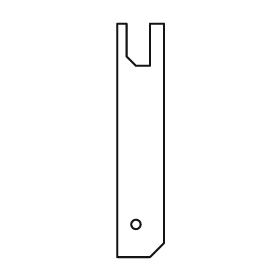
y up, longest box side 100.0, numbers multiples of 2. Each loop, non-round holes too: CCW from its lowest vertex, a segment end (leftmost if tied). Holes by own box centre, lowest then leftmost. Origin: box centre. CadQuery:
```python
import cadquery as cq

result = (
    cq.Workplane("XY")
    .moveTo(-10.0, -50.0)
    .lineTo(4.0, -50.0)
    .lineTo(10.0, -44.0)
    .lineTo(10.0, 50.0)
    .lineTo(4.0, 50.0)
    .lineTo(4.0, 32.0)
    .lineTo(-2.0, 32.0)
    .lineTo(-6.0, 36.0)
    .lineTo(-6.0, 50.0)
    .lineTo(-10.0, 50.0)
    .close()
    .moveTo(-2.0, -36.0)
    .circle(2.0)
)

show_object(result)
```